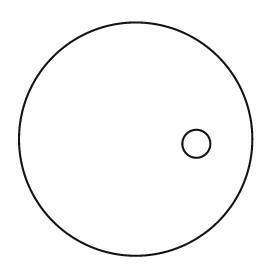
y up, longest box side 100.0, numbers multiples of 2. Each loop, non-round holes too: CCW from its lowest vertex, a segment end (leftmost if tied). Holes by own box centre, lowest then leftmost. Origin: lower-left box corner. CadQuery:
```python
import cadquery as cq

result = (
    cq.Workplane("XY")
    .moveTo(50.0, 50.0)
    .circle(50.0)
    .moveTo(76.0, 48.0)
    .circle(6.0)
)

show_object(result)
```